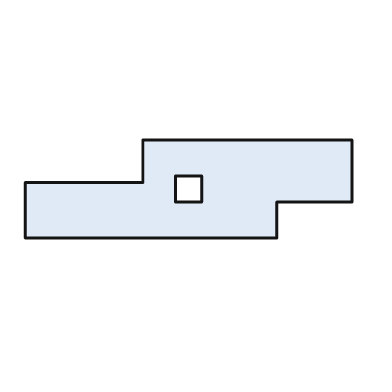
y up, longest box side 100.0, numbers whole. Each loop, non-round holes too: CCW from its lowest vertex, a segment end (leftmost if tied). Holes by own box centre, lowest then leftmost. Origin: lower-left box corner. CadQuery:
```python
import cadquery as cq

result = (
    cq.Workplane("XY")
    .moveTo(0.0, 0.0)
    .lineTo(77.0, 0.0)
    .lineTo(77.0, 11.0)
    .lineTo(100.0, 11.0)
    .lineTo(100.0, 30.0)
    .lineTo(36.0, 30.0)
    .lineTo(36.0, 17.0)
    .lineTo(0.0, 17.0)
    .close()
    .moveTo(46.0, 11.0)
    .lineTo(54.0, 11.0)
    .lineTo(54.0, 19.0)
    .lineTo(46.0, 19.0)
    .close()
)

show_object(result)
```